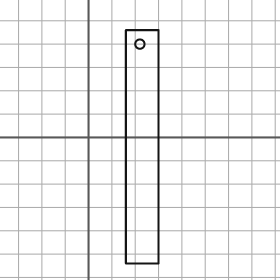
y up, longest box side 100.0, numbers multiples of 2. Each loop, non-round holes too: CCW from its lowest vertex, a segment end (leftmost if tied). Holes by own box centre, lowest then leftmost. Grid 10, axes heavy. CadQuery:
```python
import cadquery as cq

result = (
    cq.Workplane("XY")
    .moveTo(16.0, -54.0)
    .lineTo(30.0, -54.0)
    .lineTo(30.0, 46.0)
    .lineTo(16.0, 46.0)
    .close()
    .moveTo(22.0, 40.0)
    .circle(2.0)
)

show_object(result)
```